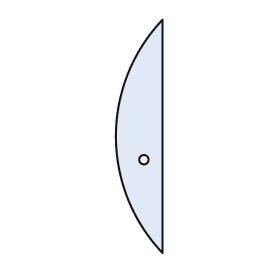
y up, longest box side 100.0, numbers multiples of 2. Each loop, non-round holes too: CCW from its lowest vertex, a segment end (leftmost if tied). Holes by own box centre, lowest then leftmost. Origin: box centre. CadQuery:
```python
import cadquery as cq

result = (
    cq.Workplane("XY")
    .moveTo(10.0, -50.0)
    .lineTo(10.0, 50.0)
    .threePointArc((-10.0, 0.0), (10.0, -50.0))
    .close()
    .moveTo(2.0, -10.0)
    .circle(2.0)
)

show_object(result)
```